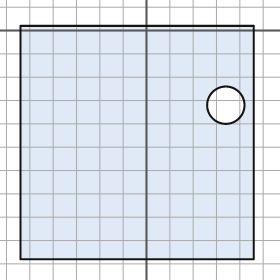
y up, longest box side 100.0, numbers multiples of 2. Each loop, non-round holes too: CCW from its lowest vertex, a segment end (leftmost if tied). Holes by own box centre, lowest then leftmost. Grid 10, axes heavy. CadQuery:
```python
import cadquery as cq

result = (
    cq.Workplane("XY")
    .moveTo(-54.0, -98.0)
    .lineTo(46.0, -98.0)
    .lineTo(46.0, 2.0)
    .lineTo(-54.0, 2.0)
    .close()
    .moveTo(34.0, -32.0)
    .circle(8.0)
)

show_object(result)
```